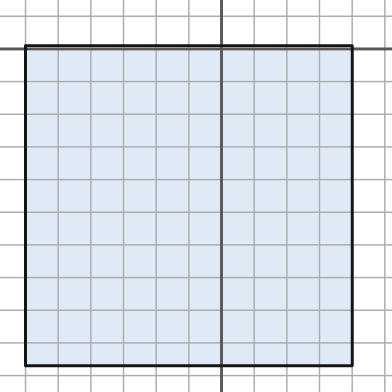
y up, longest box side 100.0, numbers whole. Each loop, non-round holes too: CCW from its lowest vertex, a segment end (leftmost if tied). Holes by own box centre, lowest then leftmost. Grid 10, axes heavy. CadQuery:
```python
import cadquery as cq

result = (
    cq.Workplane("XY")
    .moveTo(-60.0, -97.0)
    .lineTo(40.0, -97.0)
    .lineTo(40.0, 1.0)
    .lineTo(-60.0, 1.0)
    .close()
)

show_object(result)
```